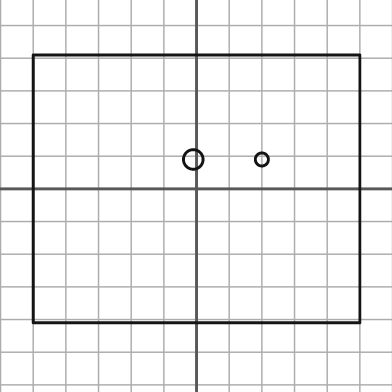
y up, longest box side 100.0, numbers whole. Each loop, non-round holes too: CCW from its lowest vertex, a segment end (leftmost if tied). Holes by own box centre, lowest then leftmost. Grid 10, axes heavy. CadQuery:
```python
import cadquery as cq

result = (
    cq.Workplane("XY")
    .moveTo(-50.0, -41.0)
    .lineTo(50.0, -41.0)
    .lineTo(50.0, 41.0)
    .lineTo(-50.0, 41.0)
    .close()
    .moveTo(-1.0, 9.0)
    .circle(3.0)
    .moveTo(20.0, 9.0)
    .circle(2.0)
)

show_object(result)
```